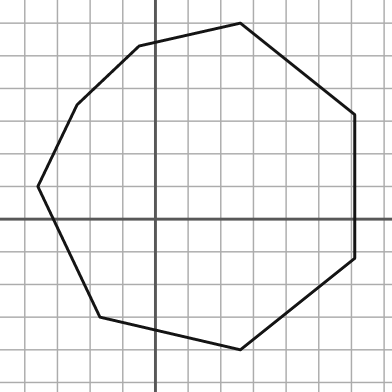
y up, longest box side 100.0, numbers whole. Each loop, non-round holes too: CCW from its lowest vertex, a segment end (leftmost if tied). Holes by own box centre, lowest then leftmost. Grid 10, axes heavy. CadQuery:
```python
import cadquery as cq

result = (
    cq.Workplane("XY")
    .moveTo(26.0, -40.0)
    .lineTo(61.0, -12.0)
    .lineTo(61.0, 32.0)
    .lineTo(26.0, 60.0)
    .lineTo(-5.0, 53.0)
    .lineTo(-24.0, 35.0)
    .lineTo(-36.0, 10.0)
    .lineTo(-17.0, -30.0)
    .close()
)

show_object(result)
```